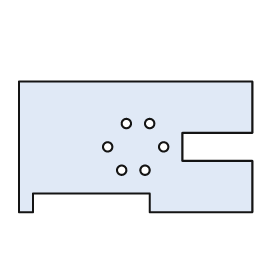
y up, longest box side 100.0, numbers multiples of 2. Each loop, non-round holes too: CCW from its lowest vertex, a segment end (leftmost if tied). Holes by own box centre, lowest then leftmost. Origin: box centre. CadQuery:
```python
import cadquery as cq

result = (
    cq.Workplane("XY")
    .moveTo(-50.0, -28.0)
    .lineTo(-44.0, -28.0)
    .lineTo(-44.0, -20.0)
    .lineTo(6.0, -20.0)
    .lineTo(6.0, -28.0)
    .lineTo(50.0, -28.0)
    .lineTo(50.0, -6.0)
    .lineTo(20.0, -6.0)
    .lineTo(20.0, 6.0)
    .lineTo(50.0, 6.0)
    .lineTo(50.0, 28.0)
    .lineTo(-50.0, 28.0)
    .close()
    .moveTo(-6.0, -10.0)
    .circle(2.0)
    .moveTo(4.0, -10.0)
    .circle(2.0)
    .moveTo(-12.0, 0.0)
    .circle(2.0)
    .moveTo(12.0, 0.0)
    .circle(2.0)
    .moveTo(-4.0, 10.0)
    .circle(2.0)
    .moveTo(6.0, 10.0)
    .circle(2.0)
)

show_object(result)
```